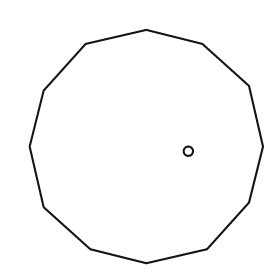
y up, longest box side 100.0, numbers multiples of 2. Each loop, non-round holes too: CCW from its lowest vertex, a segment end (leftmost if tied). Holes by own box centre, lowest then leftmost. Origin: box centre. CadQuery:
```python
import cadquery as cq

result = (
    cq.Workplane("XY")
    .moveTo(0.0, -50.0)
    .lineTo(26.0, -44.0)
    .lineTo(44.0, -24.0)
    .lineTo(50.0, 0.0)
    .lineTo(44.0, 26.0)
    .lineTo(24.0, 44.0)
    .lineTo(0.0, 50.0)
    .lineTo(-26.0, 44.0)
    .lineTo(-44.0, 24.0)
    .lineTo(-50.0, 0.0)
    .lineTo(-44.0, -26.0)
    .lineTo(-24.0, -44.0)
    .close()
    .moveTo(18.0, -2.0)
    .circle(2.0)
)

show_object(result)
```